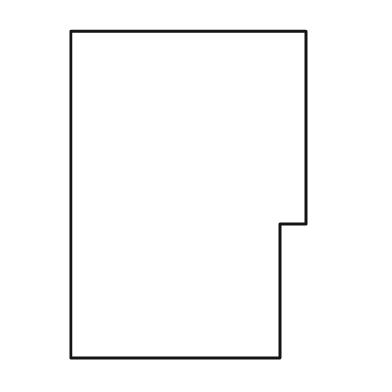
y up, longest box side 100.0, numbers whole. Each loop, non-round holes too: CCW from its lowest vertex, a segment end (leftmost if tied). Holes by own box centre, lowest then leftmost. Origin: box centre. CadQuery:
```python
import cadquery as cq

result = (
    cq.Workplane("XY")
    .moveTo(-36.0, -50.0)
    .lineTo(28.0, -50.0)
    .lineTo(28.0, -9.0)
    .lineTo(36.0, -9.0)
    .lineTo(36.0, 50.0)
    .lineTo(-36.0, 50.0)
    .close()
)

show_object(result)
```